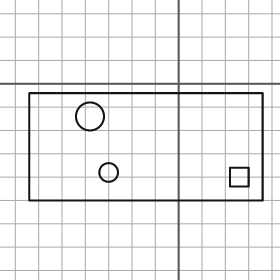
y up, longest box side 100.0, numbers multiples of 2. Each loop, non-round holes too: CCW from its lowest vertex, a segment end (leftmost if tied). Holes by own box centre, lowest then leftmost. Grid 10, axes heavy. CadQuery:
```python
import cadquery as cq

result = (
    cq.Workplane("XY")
    .moveTo(-64.0, -50.0)
    .lineTo(36.0, -50.0)
    .lineTo(36.0, -4.0)
    .lineTo(-64.0, -4.0)
    .close()
    .moveTo(22.0, -44.0)
    .lineTo(30.0, -44.0)
    .lineTo(30.0, -36.0)
    .lineTo(22.0, -36.0)
    .close()
    .moveTo(-30.0, -38.0)
    .circle(4.0)
    .moveTo(-38.0, -14.0)
    .circle(6.0)
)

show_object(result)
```